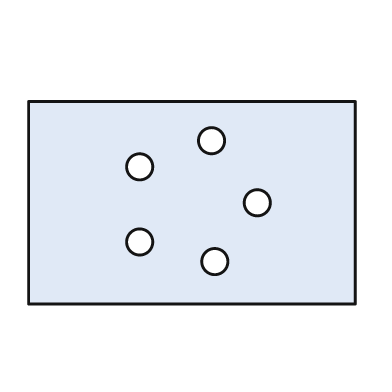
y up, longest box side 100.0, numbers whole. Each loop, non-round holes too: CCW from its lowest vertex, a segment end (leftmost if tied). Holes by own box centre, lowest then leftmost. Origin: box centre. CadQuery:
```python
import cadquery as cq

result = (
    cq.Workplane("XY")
    .moveTo(-50.0, -31.0)
    .lineTo(50.0, -31.0)
    .lineTo(50.0, 31.0)
    .lineTo(-50.0, 31.0)
    .close()
    .moveTo(7.0, -18.0)
    .circle(4.0)
    .moveTo(-16.0, -12.0)
    .circle(4.0)
    .moveTo(20.0, 0.0)
    .circle(4.0)
    .moveTo(-16.0, 11.0)
    .circle(4.0)
    .moveTo(6.0, 19.0)
    .circle(4.0)
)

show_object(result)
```